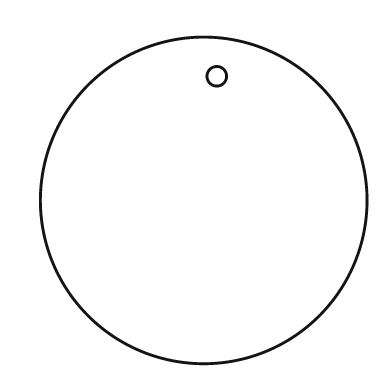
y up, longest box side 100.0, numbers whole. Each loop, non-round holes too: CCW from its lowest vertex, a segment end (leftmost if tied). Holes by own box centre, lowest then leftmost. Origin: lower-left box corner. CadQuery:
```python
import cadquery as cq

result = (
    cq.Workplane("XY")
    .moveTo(50.0, 50.0)
    .circle(50.0)
    .moveTo(54.0, 88.0)
    .circle(3.0)
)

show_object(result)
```